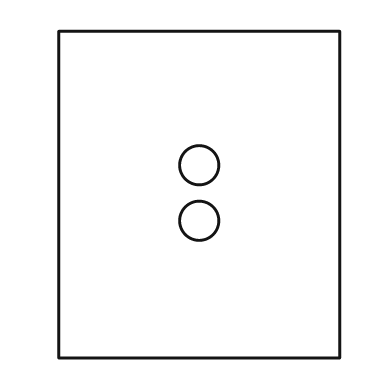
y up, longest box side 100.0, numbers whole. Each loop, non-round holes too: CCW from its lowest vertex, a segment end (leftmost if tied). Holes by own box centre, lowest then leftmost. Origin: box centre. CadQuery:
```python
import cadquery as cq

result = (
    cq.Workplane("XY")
    .moveTo(-43.0, -50.0)
    .lineTo(43.0, -50.0)
    .lineTo(43.0, 50.0)
    .lineTo(-43.0, 50.0)
    .close()
    .moveTo(0.0, -8.0)
    .circle(6.0)
    .moveTo(0.0, 9.0)
    .circle(6.0)
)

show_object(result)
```